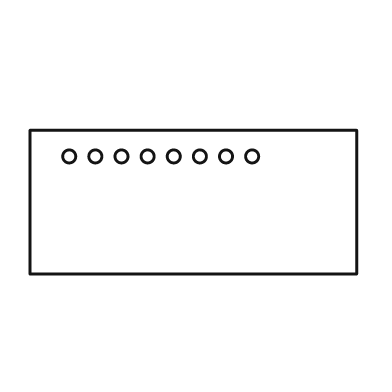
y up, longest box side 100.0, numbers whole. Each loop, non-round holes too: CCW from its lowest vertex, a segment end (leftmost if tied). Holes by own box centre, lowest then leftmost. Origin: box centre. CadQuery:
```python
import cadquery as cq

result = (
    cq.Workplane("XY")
    .moveTo(-50.0, -22.0)
    .lineTo(50.0, -22.0)
    .lineTo(50.0, 22.0)
    .lineTo(-50.0, 22.0)
    .close()
    .moveTo(-38.0, 14.0)
    .circle(2.0)
    .moveTo(-30.0, 14.0)
    .circle(2.0)
    .moveTo(-22.0, 14.0)
    .circle(2.0)
    .moveTo(-14.0, 14.0)
    .circle(2.0)
    .moveTo(-6.0, 14.0)
    .circle(2.0)
    .moveTo(2.0, 14.0)
    .circle(2.0)
    .moveTo(10.0, 14.0)
    .circle(2.0)
    .moveTo(18.0, 14.0)
    .circle(2.0)
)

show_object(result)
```